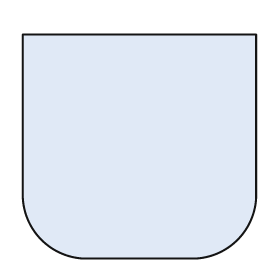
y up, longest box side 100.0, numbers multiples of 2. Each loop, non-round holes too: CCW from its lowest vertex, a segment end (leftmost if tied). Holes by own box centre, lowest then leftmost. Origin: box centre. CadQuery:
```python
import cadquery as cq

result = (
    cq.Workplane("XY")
    .moveTo(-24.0, -48.0)
    .lineTo(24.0, -48.0)
    .threePointArc((42.0, -40.0), (50.0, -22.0))
    .lineTo(50.0, 48.0)
    .lineTo(-50.0, 48.0)
    .lineTo(-50.0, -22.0)
    .threePointArc((-42.0, -40.0), (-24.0, -48.0))
    .close()
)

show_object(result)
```